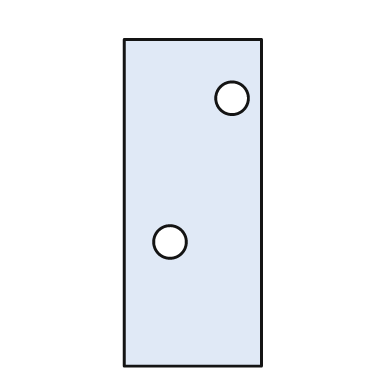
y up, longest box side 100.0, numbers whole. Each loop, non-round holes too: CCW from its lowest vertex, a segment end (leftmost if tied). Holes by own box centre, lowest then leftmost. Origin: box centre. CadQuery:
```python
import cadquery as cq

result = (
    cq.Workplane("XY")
    .moveTo(-21.0, -50.0)
    .lineTo(21.0, -50.0)
    .lineTo(21.0, 50.0)
    .lineTo(-21.0, 50.0)
    .close()
    .moveTo(-7.0, -12.0)
    .circle(5.0)
    .moveTo(12.0, 32.0)
    .circle(5.0)
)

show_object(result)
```